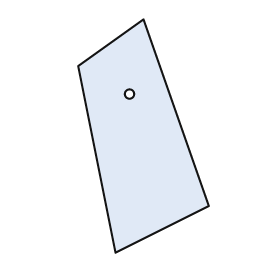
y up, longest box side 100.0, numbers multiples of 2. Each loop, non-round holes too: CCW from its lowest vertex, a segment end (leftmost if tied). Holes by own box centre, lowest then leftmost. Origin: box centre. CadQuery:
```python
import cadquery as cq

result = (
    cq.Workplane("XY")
    .moveTo(-12.0, -50.0)
    .lineTo(28.0, -30.0)
    .lineTo(0.0, 50.0)
    .lineTo(-28.0, 30.0)
    .close()
    .moveTo(-6.0, 18.0)
    .circle(2.0)
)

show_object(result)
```